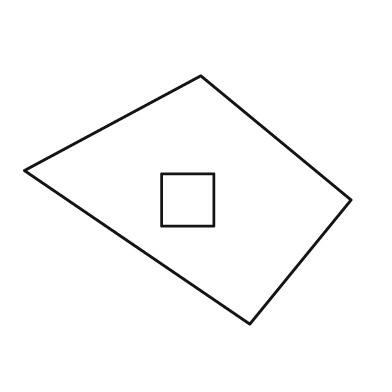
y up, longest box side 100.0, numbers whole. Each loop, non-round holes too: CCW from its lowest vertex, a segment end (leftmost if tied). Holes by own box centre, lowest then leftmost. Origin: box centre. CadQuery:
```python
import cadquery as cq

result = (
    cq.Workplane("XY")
    .moveTo(19.0, -38.0)
    .lineTo(50.0, 0.0)
    .lineTo(4.0, 38.0)
    .lineTo(-50.0, 9.0)
    .close()
    .moveTo(-8.0, -8.0)
    .lineTo(8.0, -8.0)
    .lineTo(8.0, 8.0)
    .lineTo(-8.0, 8.0)
    .close()
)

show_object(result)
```